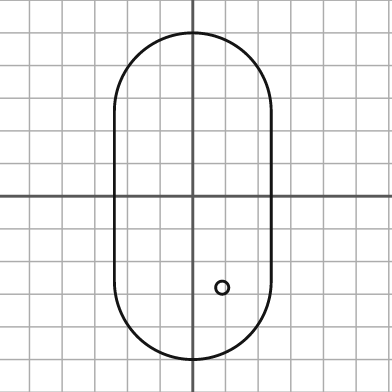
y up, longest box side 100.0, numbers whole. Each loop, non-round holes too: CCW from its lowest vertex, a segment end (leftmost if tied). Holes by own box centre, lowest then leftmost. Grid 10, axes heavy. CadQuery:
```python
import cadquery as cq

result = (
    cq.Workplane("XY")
    .moveTo(-24.0, -26.0)
    .threePointArc((0.0, -50.0), (24.0, -26.0))
    .lineTo(24.0, 26.0)
    .threePointArc((0.0, 50.0), (-24.0, 26.0))
    .close()
    .moveTo(9.0, -28.0)
    .circle(2.0)
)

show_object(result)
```